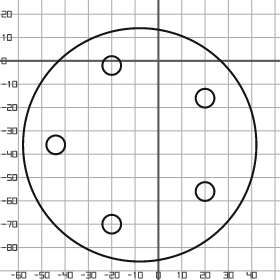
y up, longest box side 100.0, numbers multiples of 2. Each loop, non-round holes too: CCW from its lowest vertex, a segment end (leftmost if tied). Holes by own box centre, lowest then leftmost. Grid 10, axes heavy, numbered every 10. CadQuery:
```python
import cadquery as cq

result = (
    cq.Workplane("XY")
    .moveTo(-8.0, -36.0)
    .circle(50.0)
    .moveTo(-20.0, -70.0)
    .circle(4.0)
    .moveTo(20.0, -56.0)
    .circle(4.0)
    .moveTo(-44.0, -36.0)
    .circle(4.0)
    .moveTo(20.0, -16.0)
    .circle(4.0)
    .moveTo(-20.0, -2.0)
    .circle(4.0)
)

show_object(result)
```